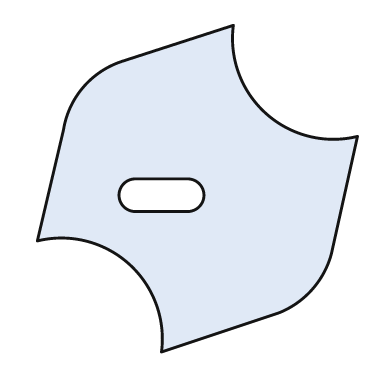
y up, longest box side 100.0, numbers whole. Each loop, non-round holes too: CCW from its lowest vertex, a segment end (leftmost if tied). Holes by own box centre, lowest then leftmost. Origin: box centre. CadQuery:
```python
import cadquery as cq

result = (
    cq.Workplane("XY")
    .moveTo(-11.0, -50.0)
    .lineTo(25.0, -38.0)
    .threePointArc((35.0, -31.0), (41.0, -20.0))
    .lineTo(49.0, 16.0)
    .threePointArc((21.0, 23.0), (11.0, 50.0))
    .lineTo(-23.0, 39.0)
    .threePointArc((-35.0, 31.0), (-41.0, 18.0))
    .lineTo(-49.0, -16.0)
    .threePointArc((-21.0, -23.0), (-11.0, -50.0))
    .close()
    .moveTo(-19.0, -7.0)
    .lineTo(-3.0, -7.0)
    .threePointArc((2.0, -2.0), (-3.0, 3.0))
    .lineTo(-19.0, 3.0)
    .threePointArc((-24.0, -2.0), (-19.0, -7.0))
    .close()
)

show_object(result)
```